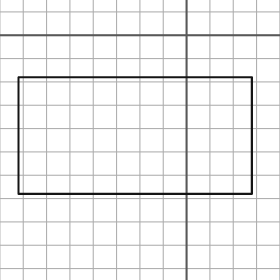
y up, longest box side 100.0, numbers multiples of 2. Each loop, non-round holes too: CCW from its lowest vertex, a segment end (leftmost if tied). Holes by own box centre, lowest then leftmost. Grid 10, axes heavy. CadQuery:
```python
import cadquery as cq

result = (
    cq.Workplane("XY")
    .moveTo(-72.0, -68.0)
    .lineTo(28.0, -68.0)
    .lineTo(28.0, -18.0)
    .lineTo(-72.0, -18.0)
    .close()
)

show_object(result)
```